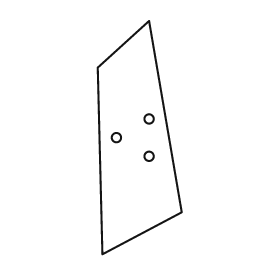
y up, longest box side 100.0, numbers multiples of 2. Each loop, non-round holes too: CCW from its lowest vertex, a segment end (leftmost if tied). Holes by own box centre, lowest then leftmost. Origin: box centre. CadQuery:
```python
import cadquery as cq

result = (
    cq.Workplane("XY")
    .moveTo(-16.0, -50.0)
    .lineTo(18.0, -32.0)
    .lineTo(4.0, 50.0)
    .lineTo(-18.0, 30.0)
    .close()
    .moveTo(4.0, -8.0)
    .circle(2.0)
    .moveTo(-10.0, 0.0)
    .circle(2.0)
    .moveTo(4.0, 8.0)
    .circle(2.0)
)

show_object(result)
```